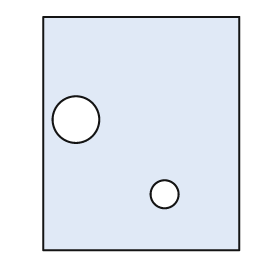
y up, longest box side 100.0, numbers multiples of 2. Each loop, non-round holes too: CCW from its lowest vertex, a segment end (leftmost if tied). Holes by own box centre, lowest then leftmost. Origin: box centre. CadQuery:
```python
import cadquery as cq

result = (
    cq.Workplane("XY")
    .moveTo(-42.0, -50.0)
    .lineTo(42.0, -50.0)
    .lineTo(42.0, 50.0)
    .lineTo(-42.0, 50.0)
    .close()
    .moveTo(10.0, -26.0)
    .circle(6.0)
    .moveTo(-28.0, 6.0)
    .circle(10.0)
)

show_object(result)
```